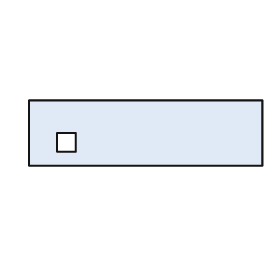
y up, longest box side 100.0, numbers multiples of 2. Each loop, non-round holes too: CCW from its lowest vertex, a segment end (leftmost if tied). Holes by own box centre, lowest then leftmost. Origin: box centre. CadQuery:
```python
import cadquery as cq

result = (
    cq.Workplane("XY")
    .moveTo(-50.0, -14.0)
    .lineTo(50.0, -14.0)
    .lineTo(50.0, 14.0)
    .lineTo(-50.0, 14.0)
    .close()
    .moveTo(-38.0, -8.0)
    .lineTo(-30.0, -8.0)
    .lineTo(-30.0, 0.0)
    .lineTo(-38.0, 0.0)
    .close()
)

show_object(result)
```